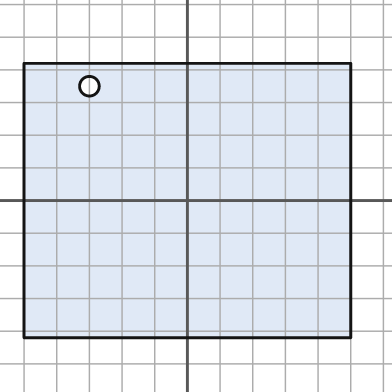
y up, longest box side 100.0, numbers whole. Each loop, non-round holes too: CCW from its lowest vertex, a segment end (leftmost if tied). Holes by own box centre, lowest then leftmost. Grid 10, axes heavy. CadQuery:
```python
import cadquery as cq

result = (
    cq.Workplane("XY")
    .moveTo(-50.0, -42.0)
    .lineTo(50.0, -42.0)
    .lineTo(50.0, 42.0)
    .lineTo(-50.0, 42.0)
    .close()
    .moveTo(-30.0, 35.0)
    .circle(3.0)
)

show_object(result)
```